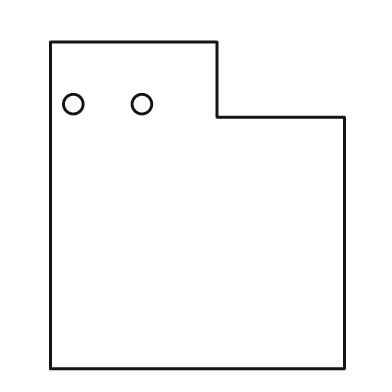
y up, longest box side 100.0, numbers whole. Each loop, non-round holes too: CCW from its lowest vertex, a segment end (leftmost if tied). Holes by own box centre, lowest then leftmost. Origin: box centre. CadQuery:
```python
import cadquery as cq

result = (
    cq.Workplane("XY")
    .moveTo(-45.0, -50.0)
    .lineTo(45.0, -50.0)
    .lineTo(45.0, 27.0)
    .lineTo(6.0, 27.0)
    .lineTo(6.0, 50.0)
    .lineTo(-45.0, 50.0)
    .close()
    .moveTo(-38.0, 31.0)
    .circle(3.0)
    .moveTo(-17.0, 31.0)
    .circle(3.0)
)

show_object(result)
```